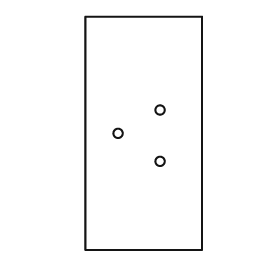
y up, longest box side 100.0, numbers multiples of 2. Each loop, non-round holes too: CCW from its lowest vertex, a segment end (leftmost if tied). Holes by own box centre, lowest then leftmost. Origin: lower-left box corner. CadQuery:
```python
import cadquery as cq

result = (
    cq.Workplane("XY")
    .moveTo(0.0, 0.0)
    .lineTo(50.0, 0.0)
    .lineTo(50.0, 100.0)
    .lineTo(0.0, 100.0)
    .close()
    .moveTo(32.0, 38.0)
    .circle(2.0)
    .moveTo(14.0, 50.0)
    .circle(2.0)
    .moveTo(32.0, 60.0)
    .circle(2.0)
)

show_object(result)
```